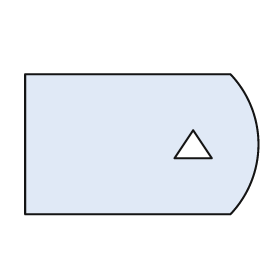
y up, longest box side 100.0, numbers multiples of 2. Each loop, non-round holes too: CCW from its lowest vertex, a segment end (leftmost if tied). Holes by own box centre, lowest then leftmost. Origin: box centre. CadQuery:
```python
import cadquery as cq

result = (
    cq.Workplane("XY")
    .moveTo(-50.0, -30.0)
    .lineTo(38.0, -30.0)
    .threePointArc((50.0, 0.0), (38.0, 30.0))
    .lineTo(-50.0, 30.0)
    .close()
    .moveTo(14.0, -6.0)
    .lineTo(30.0, -6.0)
    .lineTo(22.0, 6.0)
    .close()
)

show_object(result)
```